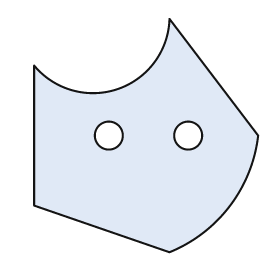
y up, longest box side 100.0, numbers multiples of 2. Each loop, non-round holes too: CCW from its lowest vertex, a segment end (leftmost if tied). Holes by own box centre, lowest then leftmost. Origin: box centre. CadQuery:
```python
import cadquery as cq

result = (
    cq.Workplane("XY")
    .moveTo(10.0, -50.0)
    .threePointArc((36.0, -30.0), (48.0, 0.0))
    .lineTo(10.0, 50.0)
    .threePointArc((-12.0, 20.0), (-48.0, 30.0))
    .lineTo(-48.0, -30.0)
    .close()
    .moveTo(-16.0, 0.0)
    .circle(6.0)
    .moveTo(18.0, 0.0)
    .circle(6.0)
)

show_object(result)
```